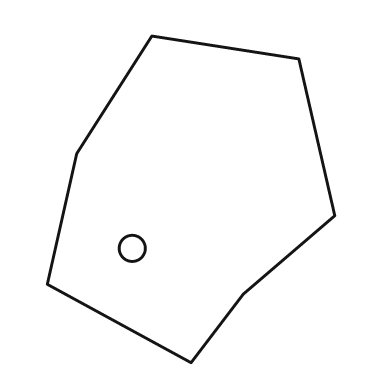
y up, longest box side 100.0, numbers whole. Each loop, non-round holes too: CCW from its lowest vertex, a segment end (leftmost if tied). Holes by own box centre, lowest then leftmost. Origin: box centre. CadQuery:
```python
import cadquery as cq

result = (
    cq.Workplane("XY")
    .moveTo(0.0, -50.0)
    .lineTo(16.0, -29.0)
    .lineTo(44.0, -5.0)
    .lineTo(33.0, 43.0)
    .lineTo(-12.0, 50.0)
    .lineTo(-35.0, 14.0)
    .lineTo(-44.0, -26.0)
    .close()
    .moveTo(-18.0, -15.0)
    .circle(4.0)
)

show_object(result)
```